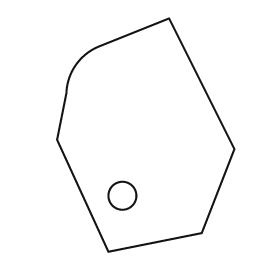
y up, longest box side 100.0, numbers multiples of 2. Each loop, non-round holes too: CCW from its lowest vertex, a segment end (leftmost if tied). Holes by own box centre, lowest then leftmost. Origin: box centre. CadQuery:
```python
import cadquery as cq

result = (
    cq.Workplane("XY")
    .moveTo(-16.0, -50.0)
    .lineTo(24.0, -42.0)
    .lineTo(38.0, -6.0)
    .lineTo(10.0, 50.0)
    .lineTo(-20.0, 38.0)
    .threePointArc((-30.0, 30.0), (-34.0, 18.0))
    .lineTo(-38.0, -2.0)
    .close()
    .moveTo(-10.0, -26.0)
    .circle(6.0)
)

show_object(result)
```